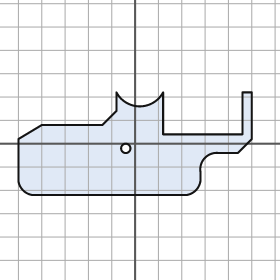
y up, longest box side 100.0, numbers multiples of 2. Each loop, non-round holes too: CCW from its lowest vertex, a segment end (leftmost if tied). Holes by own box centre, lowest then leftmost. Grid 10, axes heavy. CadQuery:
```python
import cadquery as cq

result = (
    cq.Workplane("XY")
    .moveTo(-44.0, -22.0)
    .lineTo(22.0, -22.0)
    .threePointArc((26.0, -20.0), (28.0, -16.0))
    .lineTo(28.0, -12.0)
    .threePointArc((30.0, -6.0), (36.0, -4.0))
    .lineTo(44.0, -4.0)
    .lineTo(50.0, 2.0)
    .lineTo(50.0, 22.0)
    .lineTo(46.0, 22.0)
    .lineTo(46.0, 4.0)
    .lineTo(12.0, 4.0)
    .lineTo(12.0, 22.0)
    .threePointArc((2.0, 16.0), (-8.0, 22.0))
    .lineTo(-8.0, 14.0)
    .lineTo(-14.0, 8.0)
    .lineTo(-40.0, 8.0)
    .lineTo(-50.0, 2.0)
    .lineTo(-50.0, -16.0)
    .threePointArc((-48.0, -20.0), (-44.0, -22.0))
    .close()
    .moveTo(-4.0, -2.0)
    .circle(2.0)
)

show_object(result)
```